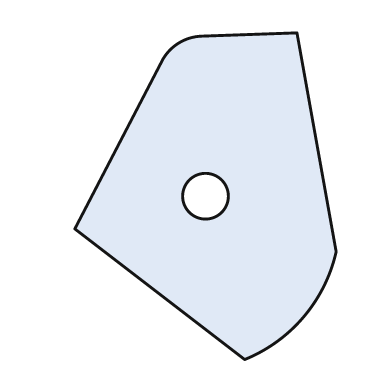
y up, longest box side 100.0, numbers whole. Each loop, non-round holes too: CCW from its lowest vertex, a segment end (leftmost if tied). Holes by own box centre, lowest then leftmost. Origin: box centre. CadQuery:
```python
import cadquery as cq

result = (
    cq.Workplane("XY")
    .moveTo(12.0, -50.0)
    .threePointArc((30.0, -37.0), (40.0, -17.0))
    .lineTo(28.0, 50.0)
    .lineTo(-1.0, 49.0)
    .threePointArc((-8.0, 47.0), (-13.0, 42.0))
    .lineTo(-40.0, -10.0)
    .close()
    .moveTo(0.0, 0.0)
    .circle(7.0)
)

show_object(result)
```